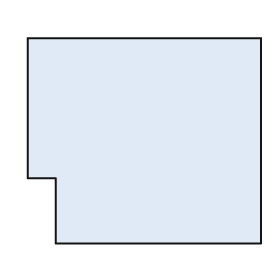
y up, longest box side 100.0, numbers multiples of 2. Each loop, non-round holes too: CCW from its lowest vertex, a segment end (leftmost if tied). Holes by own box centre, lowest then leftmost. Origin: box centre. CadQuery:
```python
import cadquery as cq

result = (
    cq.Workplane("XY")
    .moveTo(-38.0, -44.0)
    .lineTo(50.0, -44.0)
    .lineTo(50.0, 44.0)
    .lineTo(-50.0, 44.0)
    .lineTo(-50.0, -16.0)
    .lineTo(-38.0, -16.0)
    .close()
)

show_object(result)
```